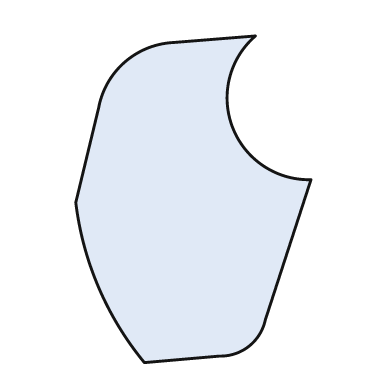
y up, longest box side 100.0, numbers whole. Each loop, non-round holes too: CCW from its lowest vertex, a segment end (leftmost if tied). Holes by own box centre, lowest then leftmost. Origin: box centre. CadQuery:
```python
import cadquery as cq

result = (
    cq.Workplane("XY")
    .moveTo(-15.0, -50.0)
    .lineTo(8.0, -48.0)
    .threePointArc((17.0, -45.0), (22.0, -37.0))
    .lineTo(36.0, 6.0)
    .threePointArc((12.0, 22.0), (19.0, 50.0))
    .lineTo(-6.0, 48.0)
    .threePointArc((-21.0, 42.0), (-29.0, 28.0))
    .lineTo(-36.0, -1.0)
    .threePointArc((-29.0, -27.0), (-15.0, -50.0))
    .close()
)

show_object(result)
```